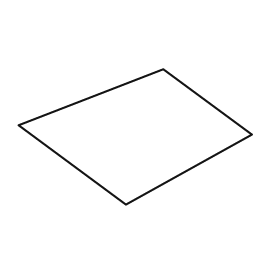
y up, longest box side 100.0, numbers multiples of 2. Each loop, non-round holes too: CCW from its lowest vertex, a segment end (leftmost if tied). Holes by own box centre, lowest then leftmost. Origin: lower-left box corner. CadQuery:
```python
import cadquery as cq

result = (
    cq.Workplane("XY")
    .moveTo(46.0, 0.0)
    .lineTo(100.0, 30.0)
    .lineTo(62.0, 58.0)
    .lineTo(0.0, 34.0)
    .close()
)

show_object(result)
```